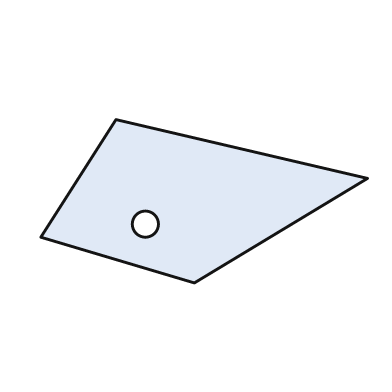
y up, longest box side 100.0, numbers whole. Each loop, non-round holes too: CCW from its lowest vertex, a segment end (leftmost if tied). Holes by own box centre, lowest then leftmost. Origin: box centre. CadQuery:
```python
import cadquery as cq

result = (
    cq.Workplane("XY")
    .moveTo(-3.0, -25.0)
    .lineTo(50.0, 7.0)
    .lineTo(-27.0, 25.0)
    .lineTo(-50.0, -11.0)
    .close()
    .moveTo(-18.0, -7.0)
    .circle(4.0)
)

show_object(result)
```